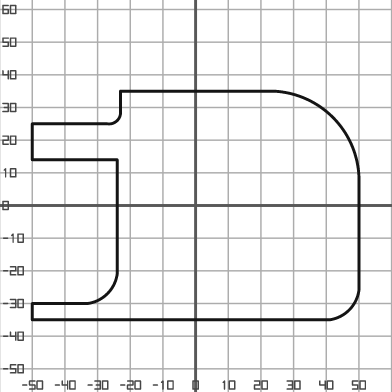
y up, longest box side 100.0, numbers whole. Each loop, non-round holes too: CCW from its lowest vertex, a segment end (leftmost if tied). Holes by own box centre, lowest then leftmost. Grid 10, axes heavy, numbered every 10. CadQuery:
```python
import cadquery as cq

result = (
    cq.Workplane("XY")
    .moveTo(-50.0, -35.0)
    .lineTo(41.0, -35.0)
    .threePointArc((47.0, -32.0), (50.0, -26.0))
    .lineTo(50.0, 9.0)
    .threePointArc((42.0, 27.0), (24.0, 35.0))
    .lineTo(-23.0, 35.0)
    .lineTo(-23.0, 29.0)
    .threePointArc((-24.0, 26.0), (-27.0, 25.0))
    .lineTo(-50.0, 25.0)
    .lineTo(-50.0, 14.0)
    .lineTo(-24.0, 14.0)
    .lineTo(-24.0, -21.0)
    .threePointArc((-27.0, -27.0), (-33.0, -30.0))
    .lineTo(-50.0, -30.0)
    .close()
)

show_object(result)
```